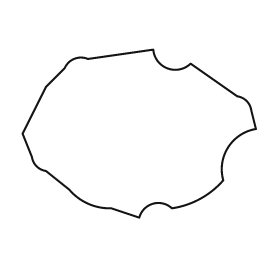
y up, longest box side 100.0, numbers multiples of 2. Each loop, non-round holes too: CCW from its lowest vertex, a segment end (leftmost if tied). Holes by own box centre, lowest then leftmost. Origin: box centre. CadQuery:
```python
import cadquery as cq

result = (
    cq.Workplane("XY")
    .moveTo(0.0, -36.0)
    .threePointArc((6.0, -30.0), (14.0, -32.0))
    .threePointArc((26.0, -28.0), (36.0, -20.0))
    .threePointArc((38.0, -6.0), (50.0, 2.0))
    .lineTo(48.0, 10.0)
    .threePointArc((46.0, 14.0), (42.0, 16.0))
    .lineTo(22.0, 30.0)
    .threePointArc((12.0, 28.0), (6.0, 36.0))
    .lineTo(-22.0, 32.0)
    .threePointArc((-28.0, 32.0), (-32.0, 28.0))
    .lineTo(-40.0, 20.0)
    .lineTo(-50.0, 0.0)
    .lineTo(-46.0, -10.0)
    .threePointArc((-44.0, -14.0), (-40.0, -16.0))
    .lineTo(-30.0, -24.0)
    .threePointArc((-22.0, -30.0), (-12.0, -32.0))
    .close()
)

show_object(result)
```